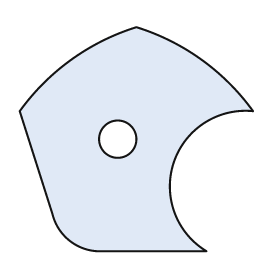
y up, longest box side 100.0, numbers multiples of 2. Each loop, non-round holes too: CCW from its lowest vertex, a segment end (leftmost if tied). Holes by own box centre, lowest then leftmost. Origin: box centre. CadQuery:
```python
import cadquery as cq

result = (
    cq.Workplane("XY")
    .moveTo(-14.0, -48.0)
    .lineTo(30.0, -48.0)
    .threePointArc((16.0, -10.0), (50.0, 12.0))
    .threePointArc((28.0, 34.0), (0.0, 48.0))
    .threePointArc((-28.0, 34.0), (-50.0, 12.0))
    .lineTo(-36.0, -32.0)
    .threePointArc((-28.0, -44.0), (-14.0, -48.0))
    .close()
    .moveTo(-8.0, 0.0)
    .circle(8.0)
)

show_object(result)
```